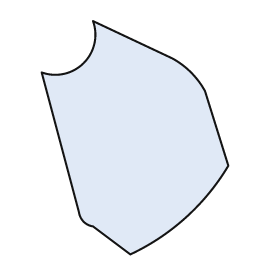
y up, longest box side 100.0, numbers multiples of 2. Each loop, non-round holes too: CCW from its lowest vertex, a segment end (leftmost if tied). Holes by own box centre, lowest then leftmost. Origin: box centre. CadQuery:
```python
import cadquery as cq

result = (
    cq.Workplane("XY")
    .moveTo(-2.0, -50.0)
    .threePointArc((22.0, -34.0), (40.0, -12.0))
    .lineTo(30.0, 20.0)
    .threePointArc((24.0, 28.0), (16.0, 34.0))
    .lineTo(-18.0, 50.0)
    .threePointArc((-22.0, 32.0), (-40.0, 28.0))
    .lineTo(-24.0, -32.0)
    .threePointArc((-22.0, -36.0), (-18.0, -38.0))
    .close()
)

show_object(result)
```